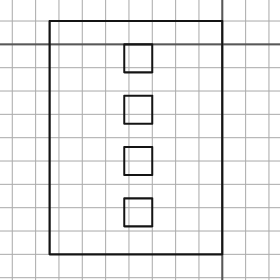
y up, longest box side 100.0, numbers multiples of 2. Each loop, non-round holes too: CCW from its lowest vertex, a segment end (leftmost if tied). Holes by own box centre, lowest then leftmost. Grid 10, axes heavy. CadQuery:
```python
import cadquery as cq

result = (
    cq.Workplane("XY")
    .moveTo(-74.0, -90.0)
    .lineTo(0.0, -90.0)
    .lineTo(0.0, 10.0)
    .lineTo(-74.0, 10.0)
    .close()
    .moveTo(-42.0, -78.0)
    .lineTo(-30.0, -78.0)
    .lineTo(-30.0, -66.0)
    .lineTo(-42.0, -66.0)
    .close()
    .moveTo(-42.0, -56.0)
    .lineTo(-30.0, -56.0)
    .lineTo(-30.0, -44.0)
    .lineTo(-42.0, -44.0)
    .close()
    .moveTo(-42.0, -34.0)
    .lineTo(-30.0, -34.0)
    .lineTo(-30.0, -22.0)
    .lineTo(-42.0, -22.0)
    .close()
    .moveTo(-42.0, -12.0)
    .lineTo(-30.0, -12.0)
    .lineTo(-30.0, 0.0)
    .lineTo(-42.0, 0.0)
    .close()
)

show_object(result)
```